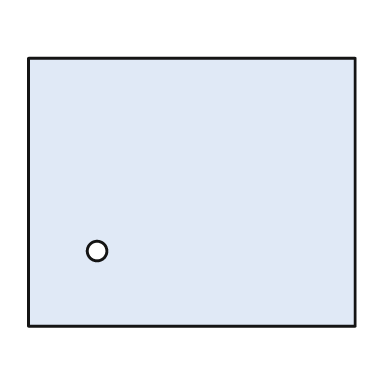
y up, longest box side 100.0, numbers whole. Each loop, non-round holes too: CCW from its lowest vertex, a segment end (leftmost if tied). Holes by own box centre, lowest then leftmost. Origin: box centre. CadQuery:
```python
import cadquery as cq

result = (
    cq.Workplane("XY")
    .moveTo(-50.0, -41.0)
    .lineTo(50.0, -41.0)
    .lineTo(50.0, 41.0)
    .lineTo(-50.0, 41.0)
    .close()
    .moveTo(-29.0, -18.0)
    .circle(3.0)
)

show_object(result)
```